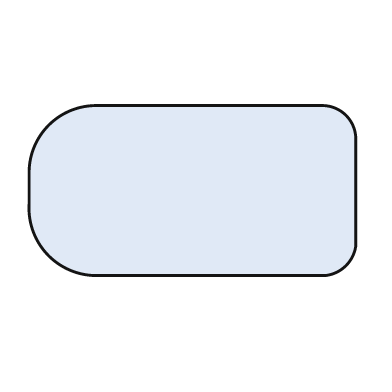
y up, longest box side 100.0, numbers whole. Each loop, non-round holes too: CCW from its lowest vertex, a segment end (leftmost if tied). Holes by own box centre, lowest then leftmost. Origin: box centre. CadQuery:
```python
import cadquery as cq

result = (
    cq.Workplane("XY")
    .moveTo(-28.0, -26.0)
    .lineTo(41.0, -26.0)
    .threePointArc((47.0, -23.0), (50.0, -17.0))
    .lineTo(50.0, 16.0)
    .threePointArc((47.0, 23.0), (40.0, 26.0))
    .lineTo(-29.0, 26.0)
    .threePointArc((-44.0, 20.0), (-50.0, 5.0))
    .lineTo(-50.0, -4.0)
    .threePointArc((-44.0, -20.0), (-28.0, -26.0))
    .close()
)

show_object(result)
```